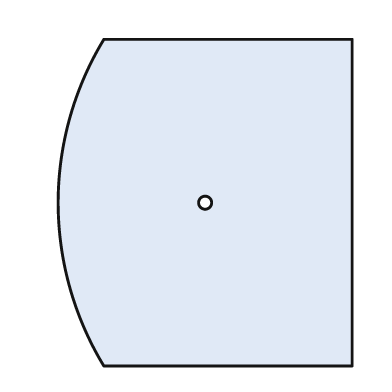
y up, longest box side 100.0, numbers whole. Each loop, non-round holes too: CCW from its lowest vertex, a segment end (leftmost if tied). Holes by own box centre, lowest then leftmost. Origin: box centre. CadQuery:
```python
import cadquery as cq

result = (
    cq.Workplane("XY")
    .moveTo(-31.0, -50.0)
    .lineTo(45.0, -50.0)
    .lineTo(45.0, 50.0)
    .lineTo(-31.0, 50.0)
    .threePointArc((-45.0, 0.0), (-31.0, -50.0))
    .close()
    .moveTo(0.0, 0.0)
    .circle(2.0)
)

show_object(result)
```